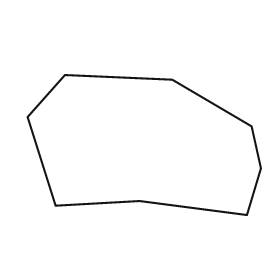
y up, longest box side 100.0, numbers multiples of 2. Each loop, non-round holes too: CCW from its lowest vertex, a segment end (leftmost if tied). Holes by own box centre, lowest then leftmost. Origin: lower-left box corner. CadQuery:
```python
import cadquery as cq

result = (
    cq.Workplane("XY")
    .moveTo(94.0, 0.0)
    .lineTo(100.0, 20.0)
    .lineTo(96.0, 38.0)
    .lineTo(62.0, 58.0)
    .lineTo(16.0, 60.0)
    .lineTo(0.0, 42.0)
    .lineTo(12.0, 4.0)
    .lineTo(48.0, 6.0)
    .close()
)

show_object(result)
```